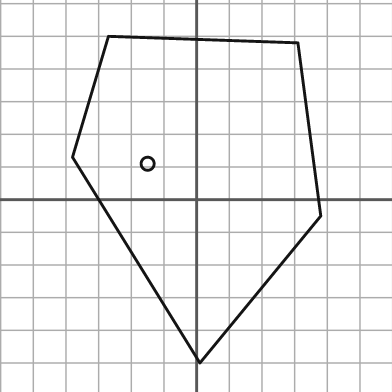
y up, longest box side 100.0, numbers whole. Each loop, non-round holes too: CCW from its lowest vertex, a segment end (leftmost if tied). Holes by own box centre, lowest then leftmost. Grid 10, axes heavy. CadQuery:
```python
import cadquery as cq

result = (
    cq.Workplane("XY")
    .moveTo(1.0, -50.0)
    .lineTo(38.0, -5.0)
    .lineTo(31.0, 48.0)
    .lineTo(-27.0, 50.0)
    .lineTo(-38.0, 13.0)
    .close()
    .moveTo(-15.0, 11.0)
    .circle(2.0)
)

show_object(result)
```